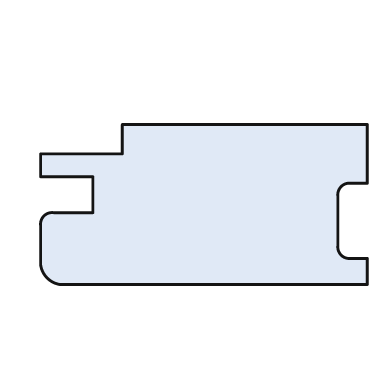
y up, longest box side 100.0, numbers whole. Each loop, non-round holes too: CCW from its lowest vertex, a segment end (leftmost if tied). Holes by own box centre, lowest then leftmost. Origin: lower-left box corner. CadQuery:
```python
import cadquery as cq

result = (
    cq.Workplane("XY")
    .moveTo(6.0, 0.0)
    .lineTo(100.0, 0.0)
    .lineTo(100.0, 8.0)
    .lineTo(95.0, 8.0)
    .threePointArc((92.0, 9.0), (91.0, 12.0))
    .lineTo(91.0, 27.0)
    .threePointArc((92.0, 30.0), (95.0, 31.0))
    .lineTo(100.0, 31.0)
    .lineTo(100.0, 49.0)
    .lineTo(25.0, 49.0)
    .lineTo(25.0, 40.0)
    .lineTo(0.0, 40.0)
    .lineTo(0.0, 33.0)
    .lineTo(16.0, 33.0)
    .lineTo(16.0, 22.0)
    .lineTo(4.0, 22.0)
    .threePointArc((1.0, 21.0), (0.0, 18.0))
    .lineTo(0.0, 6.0)
    .threePointArc((2.0, 2.0), (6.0, 0.0))
    .close()
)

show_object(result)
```